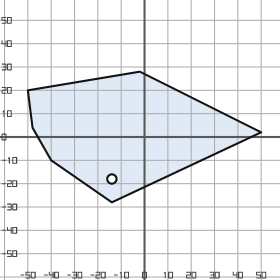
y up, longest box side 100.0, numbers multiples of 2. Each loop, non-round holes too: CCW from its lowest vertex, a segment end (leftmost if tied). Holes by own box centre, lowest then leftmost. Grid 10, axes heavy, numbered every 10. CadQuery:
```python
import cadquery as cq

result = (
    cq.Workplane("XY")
    .moveTo(-14.0, -28.0)
    .lineTo(50.0, 2.0)
    .lineTo(-2.0, 28.0)
    .lineTo(-50.0, 20.0)
    .lineTo(-48.0, 4.0)
    .lineTo(-40.0, -10.0)
    .close()
    .moveTo(-14.0, -18.0)
    .circle(2.0)
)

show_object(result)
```